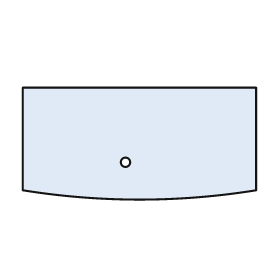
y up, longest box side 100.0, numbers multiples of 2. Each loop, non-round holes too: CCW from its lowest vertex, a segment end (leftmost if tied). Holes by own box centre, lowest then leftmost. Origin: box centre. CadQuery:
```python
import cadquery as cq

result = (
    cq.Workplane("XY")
    .moveTo(-50.0, -20.0)
    .threePointArc((0.0, -24.0), (50.0, -20.0))
    .lineTo(50.0, 24.0)
    .lineTo(-50.0, 24.0)
    .close()
    .moveTo(-6.0, -8.0)
    .circle(2.0)
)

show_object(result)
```